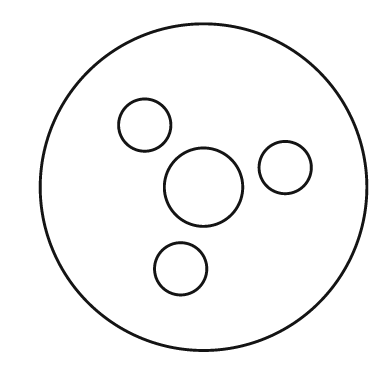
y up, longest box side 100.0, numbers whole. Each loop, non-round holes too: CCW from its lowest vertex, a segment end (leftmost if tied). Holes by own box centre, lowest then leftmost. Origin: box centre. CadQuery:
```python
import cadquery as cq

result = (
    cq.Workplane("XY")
    .moveTo(0.0, 0.0)
    .circle(50.0)
    .moveTo(-7.0, -25.0)
    .circle(8.0)
    .moveTo(0.0, 0.0)
    .circle(12.0)
    .moveTo(25.0, 6.0)
    .circle(8.0)
    .moveTo(-18.0, 19.0)
    .circle(8.0)
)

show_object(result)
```